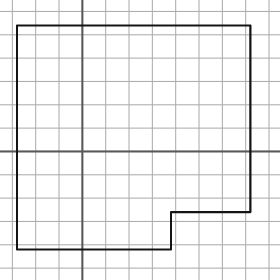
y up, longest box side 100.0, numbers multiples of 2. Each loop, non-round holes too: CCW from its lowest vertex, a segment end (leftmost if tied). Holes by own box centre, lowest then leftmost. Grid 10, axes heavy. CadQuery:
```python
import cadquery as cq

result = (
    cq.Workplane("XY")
    .moveTo(-28.0, -42.0)
    .lineTo(38.0, -42.0)
    .lineTo(38.0, -26.0)
    .lineTo(72.0, -26.0)
    .lineTo(72.0, 54.0)
    .lineTo(-28.0, 54.0)
    .close()
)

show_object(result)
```